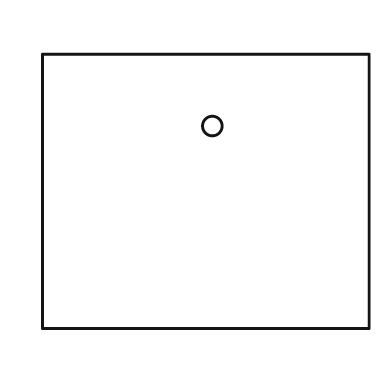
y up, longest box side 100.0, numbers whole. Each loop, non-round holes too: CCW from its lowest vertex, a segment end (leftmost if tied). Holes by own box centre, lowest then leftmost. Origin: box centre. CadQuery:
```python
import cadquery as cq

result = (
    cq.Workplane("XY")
    .moveTo(-50.0, -42.0)
    .lineTo(50.0, -42.0)
    .lineTo(50.0, 42.0)
    .lineTo(-50.0, 42.0)
    .close()
    .moveTo(2.0, 20.0)
    .circle(3.0)
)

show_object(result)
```